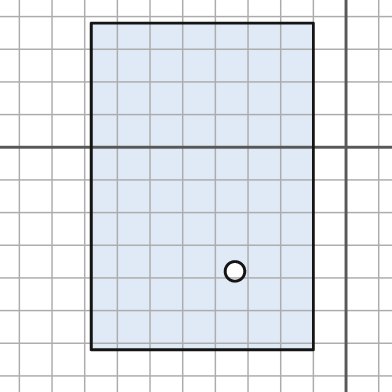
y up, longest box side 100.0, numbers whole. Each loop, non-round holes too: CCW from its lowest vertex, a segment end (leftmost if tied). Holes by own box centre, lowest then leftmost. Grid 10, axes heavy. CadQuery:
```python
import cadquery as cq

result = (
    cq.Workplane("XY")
    .moveTo(-78.0, -62.0)
    .lineTo(-10.0, -62.0)
    .lineTo(-10.0, 38.0)
    .lineTo(-78.0, 38.0)
    .close()
    .moveTo(-34.0, -38.0)
    .circle(3.0)
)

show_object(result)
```